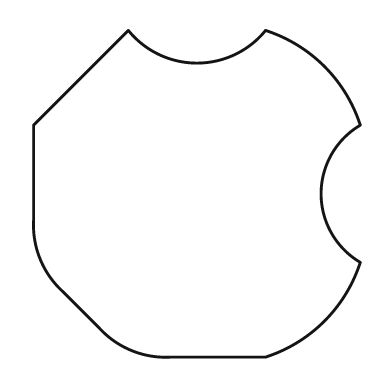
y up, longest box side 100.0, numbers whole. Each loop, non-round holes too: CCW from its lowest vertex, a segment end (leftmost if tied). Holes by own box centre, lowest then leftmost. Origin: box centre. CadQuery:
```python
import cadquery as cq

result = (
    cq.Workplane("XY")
    .moveTo(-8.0, -50.0)
    .lineTo(21.0, -50.0)
    .threePointArc((39.0, -39.0), (50.0, -21.0))
    .threePointArc((38.0, 0.0), (50.0, 21.0))
    .threePointArc((39.0, 39.0), (21.0, 50.0))
    .threePointArc((0.0, 40.0), (-21.0, 50.0))
    .lineTo(-50.0, 21.0)
    .lineTo(-50.0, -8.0)
    .threePointArc((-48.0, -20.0), (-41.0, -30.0))
    .lineTo(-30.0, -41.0)
    .threePointArc((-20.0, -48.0), (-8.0, -50.0))
    .close()
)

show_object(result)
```